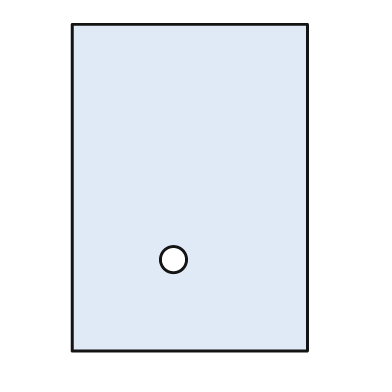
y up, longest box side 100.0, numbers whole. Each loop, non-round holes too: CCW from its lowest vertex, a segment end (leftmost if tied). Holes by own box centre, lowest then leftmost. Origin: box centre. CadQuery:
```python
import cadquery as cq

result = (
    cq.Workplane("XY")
    .moveTo(-36.0, -50.0)
    .lineTo(36.0, -50.0)
    .lineTo(36.0, 50.0)
    .lineTo(-36.0, 50.0)
    .close()
    .moveTo(-5.0, -22.0)
    .circle(4.0)
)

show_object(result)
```